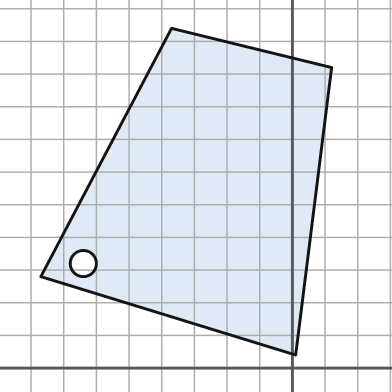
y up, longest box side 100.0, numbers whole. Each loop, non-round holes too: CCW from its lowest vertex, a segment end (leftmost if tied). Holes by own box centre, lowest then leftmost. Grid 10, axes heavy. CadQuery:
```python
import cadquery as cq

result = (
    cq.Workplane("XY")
    .moveTo(1.0, 4.0)
    .lineTo(12.0, 92.0)
    .lineTo(-37.0, 104.0)
    .lineTo(-77.0, 28.0)
    .close()
    .moveTo(-64.0, 32.0)
    .circle(4.0)
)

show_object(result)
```